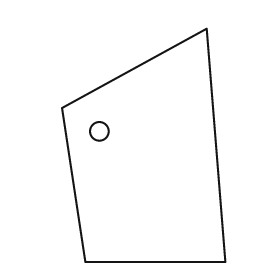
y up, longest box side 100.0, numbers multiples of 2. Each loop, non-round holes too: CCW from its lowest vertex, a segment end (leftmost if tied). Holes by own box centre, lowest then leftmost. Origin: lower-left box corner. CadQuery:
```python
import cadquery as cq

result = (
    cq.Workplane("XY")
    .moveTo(10.0, 0.0)
    .lineTo(70.0, 0.0)
    .lineTo(62.0, 100.0)
    .lineTo(0.0, 66.0)
    .close()
    .moveTo(16.0, 56.0)
    .circle(4.0)
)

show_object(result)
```